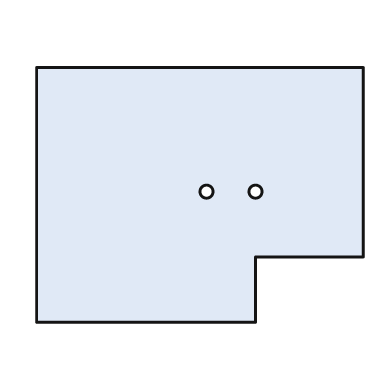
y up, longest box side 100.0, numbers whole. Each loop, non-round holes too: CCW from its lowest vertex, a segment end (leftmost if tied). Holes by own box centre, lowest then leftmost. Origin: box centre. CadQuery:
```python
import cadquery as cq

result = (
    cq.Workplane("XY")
    .moveTo(-50.0, -39.0)
    .lineTo(17.0, -39.0)
    .lineTo(17.0, -19.0)
    .lineTo(50.0, -19.0)
    .lineTo(50.0, 39.0)
    .lineTo(-50.0, 39.0)
    .close()
    .moveTo(2.0, 1.0)
    .circle(2.0)
    .moveTo(17.0, 1.0)
    .circle(2.0)
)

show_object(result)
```